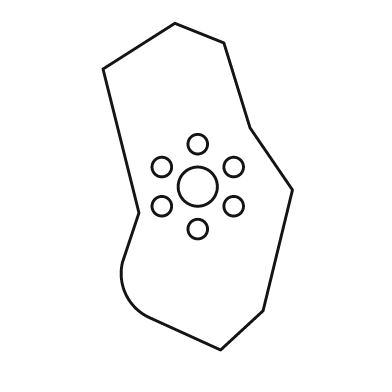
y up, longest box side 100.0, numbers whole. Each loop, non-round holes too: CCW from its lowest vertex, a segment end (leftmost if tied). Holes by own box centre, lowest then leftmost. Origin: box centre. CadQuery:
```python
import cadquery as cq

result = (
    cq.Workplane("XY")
    .moveTo(7.0, -50.0)
    .lineTo(20.0, -38.0)
    .lineTo(29.0, -1.0)
    .lineTo(16.0, 18.0)
    .lineTo(8.0, 44.0)
    .lineTo(-7.0, 50.0)
    .lineTo(-29.0, 36.0)
    .lineTo(-18.0, -8.0)
    .lineTo(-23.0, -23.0)
    .threePointArc((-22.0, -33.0), (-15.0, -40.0))
    .close()
    .moveTo(0.0, -13.0)
    .circle(3.0)
    .moveTo(-11.0, -6.0)
    .circle(3.0)
    .moveTo(11.0, -6.0)
    .circle(3.0)
    .moveTo(0.0, 0.0)
    .circle(6.0)
    .moveTo(-11.0, 6.0)
    .circle(3.0)
    .moveTo(11.0, 6.0)
    .circle(3.0)
    .moveTo(0.0, 13.0)
    .circle(3.0)
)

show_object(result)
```